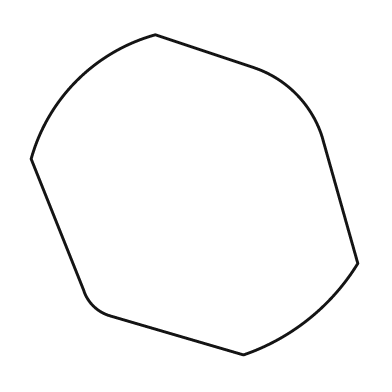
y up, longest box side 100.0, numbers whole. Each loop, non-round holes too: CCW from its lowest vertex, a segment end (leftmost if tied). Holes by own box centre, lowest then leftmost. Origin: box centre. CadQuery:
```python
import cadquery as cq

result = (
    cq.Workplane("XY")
    .moveTo(15.0, -49.0)
    .threePointArc((35.0, -38.0), (50.0, -21.0))
    .lineTo(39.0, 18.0)
    .threePointArc((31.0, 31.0), (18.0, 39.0))
    .lineTo(-12.0, 49.0)
    .threePointArc((-36.0, 35.0), (-50.0, 11.0))
    .lineTo(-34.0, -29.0)
    .threePointArc((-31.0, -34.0), (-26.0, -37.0))
    .close()
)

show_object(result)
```